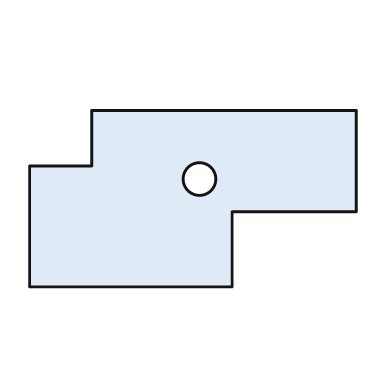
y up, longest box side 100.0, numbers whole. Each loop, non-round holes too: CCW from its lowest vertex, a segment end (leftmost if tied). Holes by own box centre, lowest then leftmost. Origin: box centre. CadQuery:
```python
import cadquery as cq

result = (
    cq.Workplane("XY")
    .moveTo(-50.0, -27.0)
    .lineTo(12.0, -27.0)
    .lineTo(12.0, -4.0)
    .lineTo(50.0, -4.0)
    .lineTo(50.0, 27.0)
    .lineTo(-31.0, 27.0)
    .lineTo(-31.0, 10.0)
    .lineTo(-50.0, 10.0)
    .close()
    .moveTo(2.0, 6.0)
    .circle(5.0)
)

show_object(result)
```